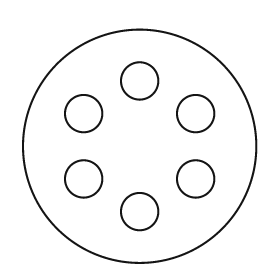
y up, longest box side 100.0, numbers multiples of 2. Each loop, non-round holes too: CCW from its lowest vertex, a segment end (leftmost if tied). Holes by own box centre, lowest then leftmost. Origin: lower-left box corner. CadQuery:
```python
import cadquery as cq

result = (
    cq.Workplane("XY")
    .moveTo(50.0, 50.0)
    .circle(50.0)
    .moveTo(50.0, 22.0)
    .circle(8.0)
    .moveTo(26.0, 36.0)
    .circle(8.0)
    .moveTo(74.0, 36.0)
    .circle(8.0)
    .moveTo(26.0, 64.0)
    .circle(8.0)
    .moveTo(74.0, 64.0)
    .circle(8.0)
    .moveTo(50.0, 78.0)
    .circle(8.0)
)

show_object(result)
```